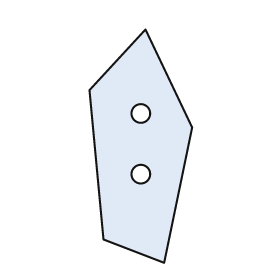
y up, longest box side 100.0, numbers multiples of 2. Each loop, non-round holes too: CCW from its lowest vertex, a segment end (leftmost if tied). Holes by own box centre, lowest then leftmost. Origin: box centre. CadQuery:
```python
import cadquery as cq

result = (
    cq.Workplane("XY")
    .moveTo(10.0, -50.0)
    .lineTo(22.0, 8.0)
    .lineTo(2.0, 50.0)
    .lineTo(-22.0, 24.0)
    .lineTo(-16.0, -40.0)
    .close()
    .moveTo(0.0, -12.0)
    .circle(4.0)
    .moveTo(0.0, 14.0)
    .circle(4.0)
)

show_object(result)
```